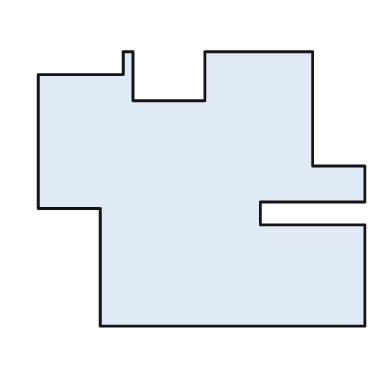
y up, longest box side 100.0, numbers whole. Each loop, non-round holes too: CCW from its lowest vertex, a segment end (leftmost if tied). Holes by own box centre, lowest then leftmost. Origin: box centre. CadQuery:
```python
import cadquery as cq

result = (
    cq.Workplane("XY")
    .moveTo(-31.0, -42.0)
    .lineTo(50.0, -42.0)
    .lineTo(50.0, -11.0)
    .lineTo(18.0, -11.0)
    .lineTo(18.0, -4.0)
    .lineTo(50.0, -4.0)
    .lineTo(50.0, 7.0)
    .lineTo(34.0, 7.0)
    .lineTo(34.0, 42.0)
    .lineTo(1.0, 42.0)
    .lineTo(1.0, 27.0)
    .lineTo(-21.0, 27.0)
    .lineTo(-21.0, 42.0)
    .lineTo(-24.0, 42.0)
    .lineTo(-24.0, 35.0)
    .lineTo(-50.0, 35.0)
    .lineTo(-50.0, -6.0)
    .lineTo(-31.0, -6.0)
    .close()
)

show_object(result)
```